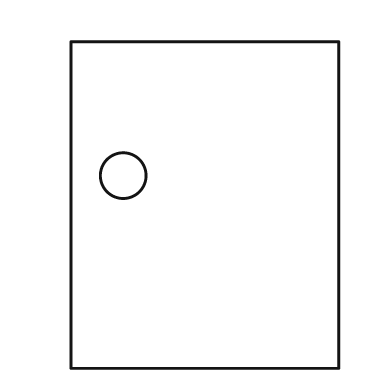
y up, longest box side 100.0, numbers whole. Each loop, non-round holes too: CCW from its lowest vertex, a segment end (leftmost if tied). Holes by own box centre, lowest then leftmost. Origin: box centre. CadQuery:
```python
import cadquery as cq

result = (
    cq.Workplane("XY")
    .moveTo(-41.0, -50.0)
    .lineTo(41.0, -50.0)
    .lineTo(41.0, 50.0)
    .lineTo(-41.0, 50.0)
    .close()
    .moveTo(-25.0, 9.0)
    .circle(7.0)
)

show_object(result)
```